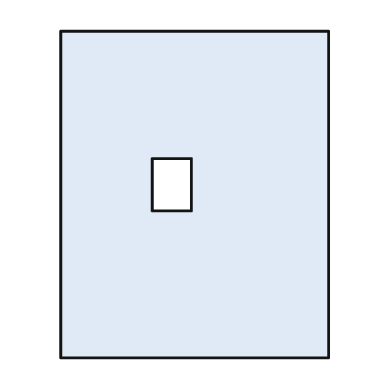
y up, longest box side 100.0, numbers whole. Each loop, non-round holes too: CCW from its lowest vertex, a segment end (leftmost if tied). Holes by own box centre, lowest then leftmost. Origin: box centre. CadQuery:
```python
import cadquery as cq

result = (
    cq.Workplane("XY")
    .moveTo(-41.0, -50.0)
    .lineTo(41.0, -50.0)
    .lineTo(41.0, 50.0)
    .lineTo(-41.0, 50.0)
    .close()
    .moveTo(-13.0, -5.0)
    .lineTo(-1.0, -5.0)
    .lineTo(-1.0, 11.0)
    .lineTo(-13.0, 11.0)
    .close()
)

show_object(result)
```